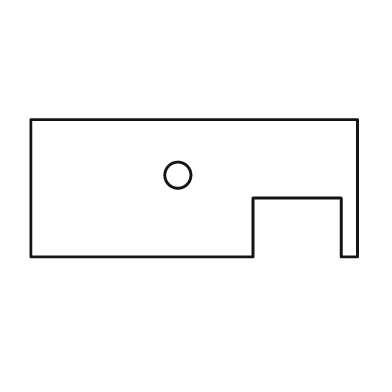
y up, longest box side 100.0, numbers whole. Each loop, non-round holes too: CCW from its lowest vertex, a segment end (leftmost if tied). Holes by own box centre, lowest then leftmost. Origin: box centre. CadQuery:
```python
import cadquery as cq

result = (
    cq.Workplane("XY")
    .moveTo(-50.0, -21.0)
    .lineTo(18.0, -21.0)
    .lineTo(18.0, -3.0)
    .lineTo(45.0, -3.0)
    .lineTo(45.0, -21.0)
    .lineTo(50.0, -21.0)
    .lineTo(50.0, 21.0)
    .lineTo(-50.0, 21.0)
    .close()
    .moveTo(-5.0, 4.0)
    .circle(4.0)
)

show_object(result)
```